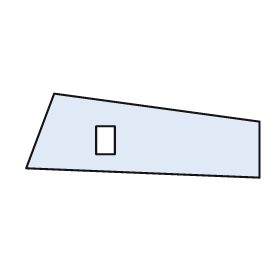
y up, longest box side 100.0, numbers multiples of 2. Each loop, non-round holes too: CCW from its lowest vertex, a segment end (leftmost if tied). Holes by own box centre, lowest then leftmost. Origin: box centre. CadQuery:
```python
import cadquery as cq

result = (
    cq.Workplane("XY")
    .moveTo(50.0, -18.0)
    .lineTo(50.0, 6.0)
    .lineTo(-38.0, 18.0)
    .lineTo(-50.0, -14.0)
    .close()
    .moveTo(-20.0, -8.0)
    .lineTo(-12.0, -8.0)
    .lineTo(-12.0, 4.0)
    .lineTo(-20.0, 4.0)
    .close()
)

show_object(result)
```